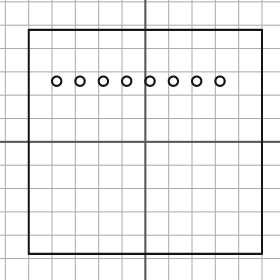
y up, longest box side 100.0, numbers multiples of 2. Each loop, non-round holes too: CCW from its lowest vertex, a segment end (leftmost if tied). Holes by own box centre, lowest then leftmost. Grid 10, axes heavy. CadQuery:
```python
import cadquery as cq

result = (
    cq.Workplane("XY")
    .moveTo(-50.0, -48.0)
    .lineTo(50.0, -48.0)
    .lineTo(50.0, 48.0)
    .lineTo(-50.0, 48.0)
    .close()
    .moveTo(-38.0, 26.0)
    .circle(2.0)
    .moveTo(-28.0, 26.0)
    .circle(2.0)
    .moveTo(-18.0, 26.0)
    .circle(2.0)
    .moveTo(-8.0, 26.0)
    .circle(2.0)
    .moveTo(2.0, 26.0)
    .circle(2.0)
    .moveTo(12.0, 26.0)
    .circle(2.0)
    .moveTo(22.0, 26.0)
    .circle(2.0)
    .moveTo(32.0, 26.0)
    .circle(2.0)
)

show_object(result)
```